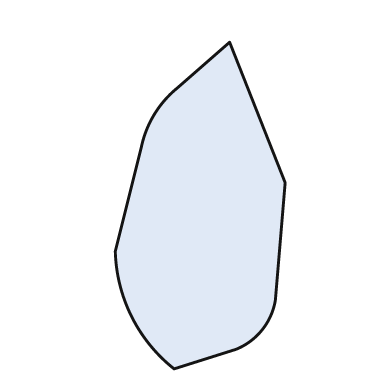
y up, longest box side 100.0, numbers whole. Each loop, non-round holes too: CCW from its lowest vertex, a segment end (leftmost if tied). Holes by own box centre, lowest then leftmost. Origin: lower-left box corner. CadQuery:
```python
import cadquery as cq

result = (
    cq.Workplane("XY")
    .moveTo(18.0, 0.0)
    .lineTo(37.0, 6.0)
    .threePointArc((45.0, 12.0), (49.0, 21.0))
    .lineTo(52.0, 57.0)
    .lineTo(35.0, 100.0)
    .lineTo(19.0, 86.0)
    .threePointArc((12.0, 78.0), (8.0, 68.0))
    .lineTo(0.0, 36.0)
    .threePointArc((5.0, 16.0), (18.0, 0.0))
    .close()
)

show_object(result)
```